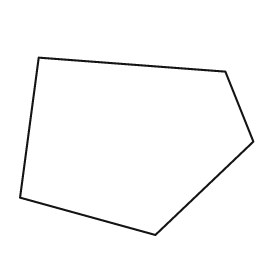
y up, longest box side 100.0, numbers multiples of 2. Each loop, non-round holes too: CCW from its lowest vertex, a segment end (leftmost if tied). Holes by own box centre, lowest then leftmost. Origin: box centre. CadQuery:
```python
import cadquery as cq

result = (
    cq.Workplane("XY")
    .moveTo(8.0, -38.0)
    .lineTo(50.0, 2.0)
    .lineTo(38.0, 32.0)
    .lineTo(-42.0, 38.0)
    .lineTo(-50.0, -22.0)
    .close()
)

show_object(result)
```